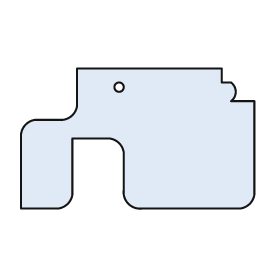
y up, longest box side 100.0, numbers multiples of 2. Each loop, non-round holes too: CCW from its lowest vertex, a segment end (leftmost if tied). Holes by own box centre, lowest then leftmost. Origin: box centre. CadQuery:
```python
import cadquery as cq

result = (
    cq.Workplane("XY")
    .moveTo(-50.0, -30.0)
    .lineTo(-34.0, -30.0)
    .threePointArc((-30.0, -28.0), (-28.0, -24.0))
    .lineTo(-28.0, 0.0)
    .lineTo(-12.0, 0.0)
    .threePointArc((-8.0, -2.0), (-6.0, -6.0))
    .lineTo(-6.0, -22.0)
    .threePointArc((-4.0, -28.0), (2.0, -30.0))
    .lineTo(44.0, -30.0)
    .threePointArc((48.0, -28.0), (50.0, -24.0))
    .lineTo(50.0, 16.0)
    .lineTo(40.0, 16.0)
    .threePointArc((42.0, 20.0), (40.0, 24.0))
    .lineTo(36.0, 24.0)
    .lineTo(36.0, 30.0)
    .lineTo(-26.0, 30.0)
    .lineTo(-26.0, 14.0)
    .threePointArc((-28.0, 10.0), (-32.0, 8.0))
    .lineTo(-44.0, 8.0)
    .threePointArc((-48.0, 6.0), (-50.0, 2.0))
    .close()
    .moveTo(-8.0, 22.0)
    .circle(2.0)
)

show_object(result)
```